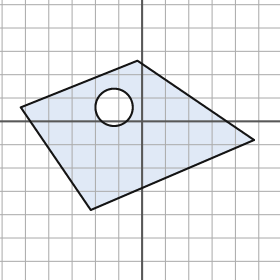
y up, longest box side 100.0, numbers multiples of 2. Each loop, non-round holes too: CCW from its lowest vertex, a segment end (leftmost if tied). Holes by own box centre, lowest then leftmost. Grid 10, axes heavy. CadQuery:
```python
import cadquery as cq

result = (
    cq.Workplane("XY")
    .moveTo(-22.0, -38.0)
    .lineTo(48.0, -8.0)
    .lineTo(-2.0, 26.0)
    .lineTo(-52.0, 6.0)
    .close()
    .moveTo(-12.0, 6.0)
    .circle(8.0)
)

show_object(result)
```